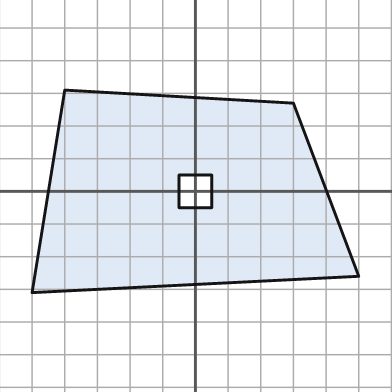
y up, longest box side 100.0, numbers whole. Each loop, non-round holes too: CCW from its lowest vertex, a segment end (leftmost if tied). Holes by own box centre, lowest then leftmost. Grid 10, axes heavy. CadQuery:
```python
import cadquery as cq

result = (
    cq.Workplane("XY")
    .moveTo(-50.0, -31.0)
    .lineTo(50.0, -26.0)
    .lineTo(30.0, 27.0)
    .lineTo(-40.0, 31.0)
    .close()
    .moveTo(-5.0, -5.0)
    .lineTo(5.0, -5.0)
    .lineTo(5.0, 5.0)
    .lineTo(-5.0, 5.0)
    .close()
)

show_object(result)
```